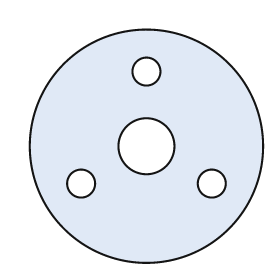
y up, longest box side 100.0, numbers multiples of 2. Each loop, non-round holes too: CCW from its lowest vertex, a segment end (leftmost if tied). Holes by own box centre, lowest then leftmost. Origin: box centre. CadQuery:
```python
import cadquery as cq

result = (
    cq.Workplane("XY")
    .moveTo(0.0, 0.0)
    .circle(50.0)
    .moveTo(-28.0, -16.0)
    .circle(6.0)
    .moveTo(28.0, -16.0)
    .circle(6.0)
    .moveTo(0.0, 0.0)
    .circle(12.0)
    .moveTo(0.0, 32.0)
    .circle(6.0)
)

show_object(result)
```